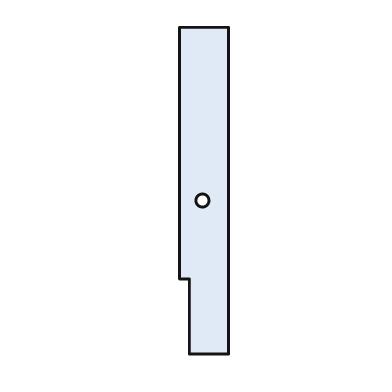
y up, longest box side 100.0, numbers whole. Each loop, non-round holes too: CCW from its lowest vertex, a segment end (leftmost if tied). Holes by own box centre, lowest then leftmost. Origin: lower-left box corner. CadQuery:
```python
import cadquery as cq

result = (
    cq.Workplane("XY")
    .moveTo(3.0, 0.0)
    .lineTo(15.0, 0.0)
    .lineTo(15.0, 100.0)
    .lineTo(0.0, 100.0)
    .lineTo(0.0, 23.0)
    .lineTo(3.0, 23.0)
    .close()
    .moveTo(7.0, 47.0)
    .circle(2.0)
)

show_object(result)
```